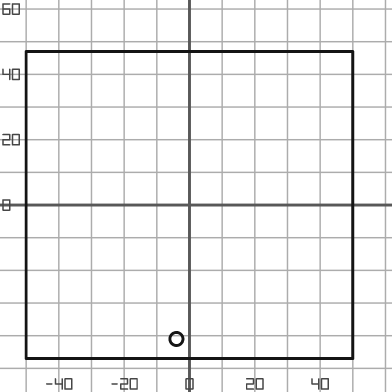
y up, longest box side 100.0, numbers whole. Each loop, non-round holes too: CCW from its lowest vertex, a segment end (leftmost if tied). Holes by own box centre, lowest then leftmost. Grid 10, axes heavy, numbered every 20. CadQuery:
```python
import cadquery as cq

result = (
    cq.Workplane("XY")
    .moveTo(-50.0, -47.0)
    .lineTo(50.0, -47.0)
    .lineTo(50.0, 47.0)
    .lineTo(-50.0, 47.0)
    .close()
    .moveTo(-4.0, -41.0)
    .circle(2.0)
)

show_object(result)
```